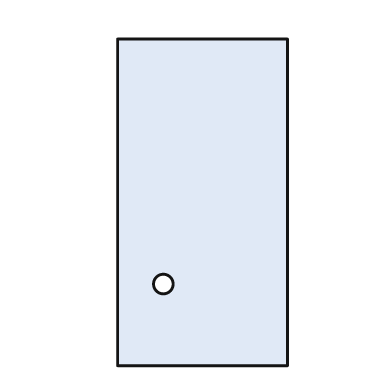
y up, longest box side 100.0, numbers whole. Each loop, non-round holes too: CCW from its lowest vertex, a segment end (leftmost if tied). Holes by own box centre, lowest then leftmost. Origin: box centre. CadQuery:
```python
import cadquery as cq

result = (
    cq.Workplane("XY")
    .moveTo(-26.0, -50.0)
    .lineTo(26.0, -50.0)
    .lineTo(26.0, 50.0)
    .lineTo(-26.0, 50.0)
    .close()
    .moveTo(-12.0, -25.0)
    .circle(3.0)
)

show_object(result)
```